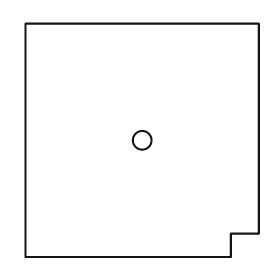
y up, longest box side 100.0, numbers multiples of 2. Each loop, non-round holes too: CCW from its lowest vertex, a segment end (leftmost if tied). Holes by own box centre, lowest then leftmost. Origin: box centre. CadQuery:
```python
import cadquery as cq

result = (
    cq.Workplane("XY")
    .moveTo(-50.0, -50.0)
    .lineTo(38.0, -50.0)
    .lineTo(38.0, -40.0)
    .lineTo(50.0, -40.0)
    .lineTo(50.0, 50.0)
    .lineTo(-50.0, 50.0)
    .close()
    .moveTo(0.0, 0.0)
    .circle(4.0)
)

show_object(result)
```